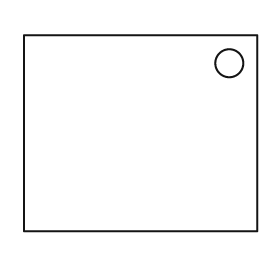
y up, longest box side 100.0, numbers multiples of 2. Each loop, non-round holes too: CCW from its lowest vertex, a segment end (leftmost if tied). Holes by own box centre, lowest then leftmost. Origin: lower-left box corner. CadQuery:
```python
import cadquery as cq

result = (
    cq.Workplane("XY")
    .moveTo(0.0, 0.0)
    .lineTo(100.0, 0.0)
    .lineTo(100.0, 84.0)
    .lineTo(0.0, 84.0)
    .close()
    .moveTo(88.0, 72.0)
    .circle(6.0)
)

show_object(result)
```